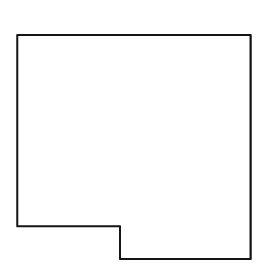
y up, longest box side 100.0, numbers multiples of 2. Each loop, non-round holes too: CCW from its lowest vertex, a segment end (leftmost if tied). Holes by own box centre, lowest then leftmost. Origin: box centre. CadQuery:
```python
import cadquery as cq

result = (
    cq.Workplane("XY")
    .moveTo(-6.0, -48.0)
    .lineTo(50.0, -48.0)
    .lineTo(50.0, 48.0)
    .lineTo(-50.0, 48.0)
    .lineTo(-50.0, -34.0)
    .lineTo(-6.0, -34.0)
    .close()
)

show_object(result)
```